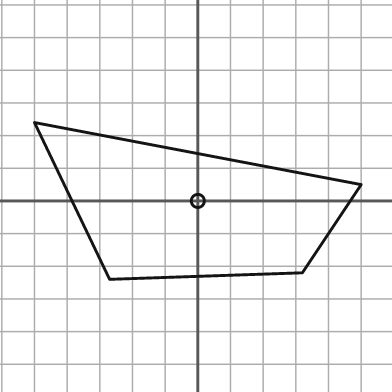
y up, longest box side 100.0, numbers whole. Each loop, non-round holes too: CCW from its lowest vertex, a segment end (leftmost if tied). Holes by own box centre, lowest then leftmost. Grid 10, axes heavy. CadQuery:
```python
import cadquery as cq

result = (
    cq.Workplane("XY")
    .moveTo(-27.0, -24.0)
    .lineTo(32.0, -22.0)
    .lineTo(50.0, 5.0)
    .lineTo(-50.0, 24.0)
    .close()
    .moveTo(0.0, 0.0)
    .circle(2.0)
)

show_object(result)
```